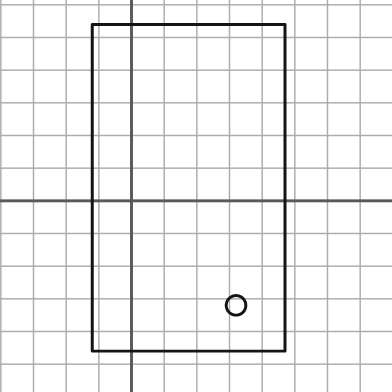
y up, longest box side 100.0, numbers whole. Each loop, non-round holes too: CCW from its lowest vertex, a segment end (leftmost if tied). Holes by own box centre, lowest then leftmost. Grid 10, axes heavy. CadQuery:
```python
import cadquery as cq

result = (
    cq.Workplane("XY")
    .moveTo(-12.0, -46.0)
    .lineTo(47.0, -46.0)
    .lineTo(47.0, 54.0)
    .lineTo(-12.0, 54.0)
    .close()
    .moveTo(32.0, -32.0)
    .circle(3.0)
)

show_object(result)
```